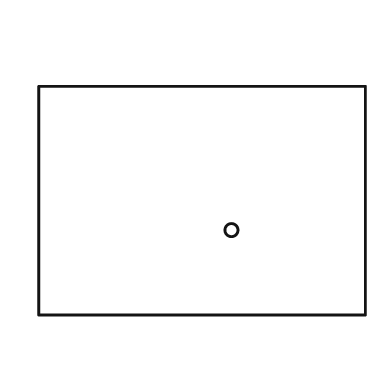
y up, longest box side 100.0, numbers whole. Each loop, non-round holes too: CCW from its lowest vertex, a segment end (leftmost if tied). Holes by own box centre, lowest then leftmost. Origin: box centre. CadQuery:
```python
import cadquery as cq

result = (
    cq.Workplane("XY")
    .moveTo(-50.0, -35.0)
    .lineTo(50.0, -35.0)
    .lineTo(50.0, 35.0)
    .lineTo(-50.0, 35.0)
    .close()
    .moveTo(9.0, -9.0)
    .circle(2.0)
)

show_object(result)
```